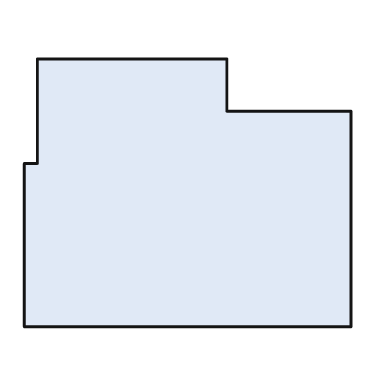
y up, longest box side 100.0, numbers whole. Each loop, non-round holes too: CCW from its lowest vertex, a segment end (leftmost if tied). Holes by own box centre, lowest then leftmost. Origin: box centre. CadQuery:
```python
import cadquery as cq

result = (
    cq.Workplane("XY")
    .moveTo(-50.0, -41.0)
    .lineTo(50.0, -41.0)
    .lineTo(50.0, 25.0)
    .lineTo(12.0, 25.0)
    .lineTo(12.0, 41.0)
    .lineTo(-46.0, 41.0)
    .lineTo(-46.0, 9.0)
    .lineTo(-50.0, 9.0)
    .close()
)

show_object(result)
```